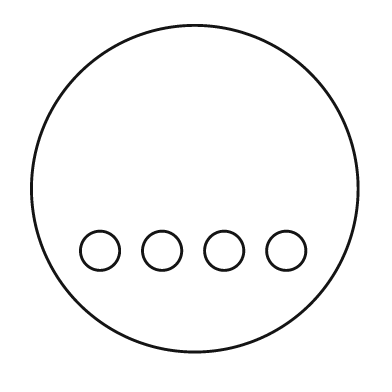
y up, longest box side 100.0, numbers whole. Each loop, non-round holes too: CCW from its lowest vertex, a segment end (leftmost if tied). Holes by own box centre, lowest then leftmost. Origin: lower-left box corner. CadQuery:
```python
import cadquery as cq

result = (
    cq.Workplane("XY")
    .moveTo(50.0, 50.0)
    .circle(50.0)
    .moveTo(21.0, 31.0)
    .circle(6.0)
    .moveTo(40.0, 31.0)
    .circle(6.0)
    .moveTo(59.0, 31.0)
    .circle(6.0)
    .moveTo(78.0, 31.0)
    .circle(6.0)
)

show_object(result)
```